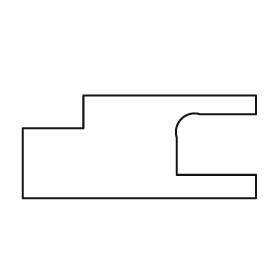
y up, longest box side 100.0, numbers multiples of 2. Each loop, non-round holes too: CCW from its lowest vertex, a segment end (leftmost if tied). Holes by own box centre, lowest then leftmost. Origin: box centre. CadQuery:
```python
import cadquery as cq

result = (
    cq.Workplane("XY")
    .moveTo(-50.0, -22.0)
    .lineTo(50.0, -22.0)
    .lineTo(50.0, -12.0)
    .lineTo(16.0, -12.0)
    .lineTo(16.0, 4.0)
    .threePointArc((18.0, 12.0), (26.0, 14.0))
    .lineTo(50.0, 14.0)
    .lineTo(50.0, 22.0)
    .lineTo(-24.0, 22.0)
    .lineTo(-24.0, 8.0)
    .lineTo(-50.0, 8.0)
    .close()
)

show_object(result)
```